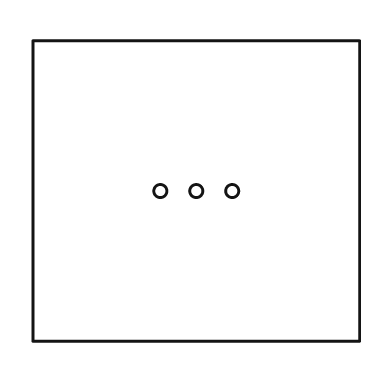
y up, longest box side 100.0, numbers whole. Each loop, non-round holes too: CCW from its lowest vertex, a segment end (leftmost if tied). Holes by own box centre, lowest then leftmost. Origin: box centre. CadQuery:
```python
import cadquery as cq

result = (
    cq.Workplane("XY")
    .moveTo(-50.0, -46.0)
    .lineTo(50.0, -46.0)
    .lineTo(50.0, 46.0)
    .lineTo(-50.0, 46.0)
    .close()
    .moveTo(-11.0, 0.0)
    .circle(2.0)
    .moveTo(0.0, 0.0)
    .circle(2.0)
    .moveTo(11.0, 0.0)
    .circle(2.0)
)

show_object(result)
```